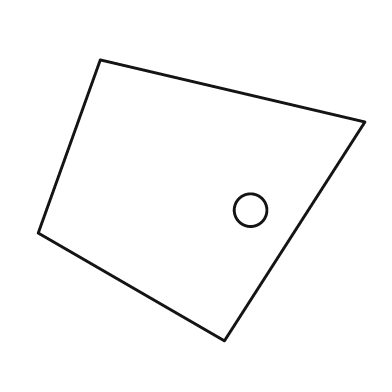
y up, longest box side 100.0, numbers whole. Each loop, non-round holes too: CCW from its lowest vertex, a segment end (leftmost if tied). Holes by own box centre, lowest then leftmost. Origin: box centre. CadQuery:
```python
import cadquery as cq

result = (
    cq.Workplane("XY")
    .moveTo(7.0, -43.0)
    .lineTo(50.0, 24.0)
    .lineTo(-31.0, 43.0)
    .lineTo(-50.0, -10.0)
    .close()
    .moveTo(15.0, -3.0)
    .circle(5.0)
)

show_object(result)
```